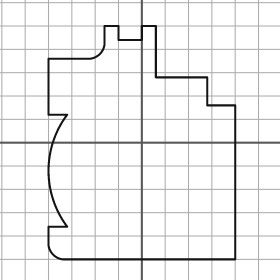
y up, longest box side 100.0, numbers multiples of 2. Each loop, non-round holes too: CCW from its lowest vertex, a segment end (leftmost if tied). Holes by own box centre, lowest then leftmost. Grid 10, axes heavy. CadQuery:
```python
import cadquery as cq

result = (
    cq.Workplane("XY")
    .moveTo(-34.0, -50.0)
    .lineTo(40.0, -50.0)
    .lineTo(40.0, 16.0)
    .lineTo(28.0, 16.0)
    .lineTo(28.0, 28.0)
    .lineTo(6.0, 28.0)
    .lineTo(6.0, 50.0)
    .lineTo(0.0, 50.0)
    .lineTo(0.0, 44.0)
    .lineTo(-10.0, 44.0)
    .lineTo(-10.0, 50.0)
    .lineTo(-16.0, 50.0)
    .lineTo(-16.0, 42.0)
    .threePointArc((-18.0, 38.0), (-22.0, 36.0))
    .lineTo(-40.0, 36.0)
    .lineTo(-40.0, 12.0)
    .lineTo(-32.0, 12.0)
    .threePointArc((-40.0, -12.0), (-32.0, -36.0))
    .lineTo(-40.0, -36.0)
    .lineTo(-40.0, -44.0)
    .threePointArc((-38.0, -48.0), (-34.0, -50.0))
    .close()
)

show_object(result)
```